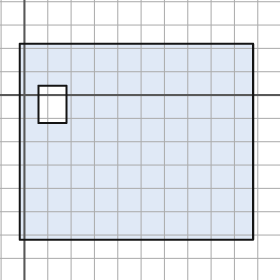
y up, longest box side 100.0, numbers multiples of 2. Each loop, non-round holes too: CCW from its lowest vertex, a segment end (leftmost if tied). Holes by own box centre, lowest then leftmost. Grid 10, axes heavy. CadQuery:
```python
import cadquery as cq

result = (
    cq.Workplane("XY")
    .moveTo(-2.0, -62.0)
    .lineTo(98.0, -62.0)
    .lineTo(98.0, 22.0)
    .lineTo(-2.0, 22.0)
    .close()
    .moveTo(6.0, -12.0)
    .lineTo(18.0, -12.0)
    .lineTo(18.0, 4.0)
    .lineTo(6.0, 4.0)
    .close()
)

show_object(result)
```